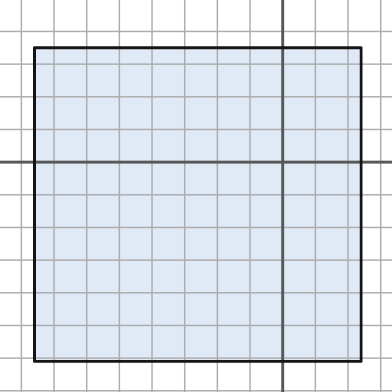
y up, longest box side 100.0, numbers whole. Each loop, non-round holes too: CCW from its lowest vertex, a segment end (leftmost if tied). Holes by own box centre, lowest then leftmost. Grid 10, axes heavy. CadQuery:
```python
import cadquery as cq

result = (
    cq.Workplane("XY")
    .moveTo(-76.0, -61.0)
    .lineTo(24.0, -61.0)
    .lineTo(24.0, 35.0)
    .lineTo(-76.0, 35.0)
    .close()
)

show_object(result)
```